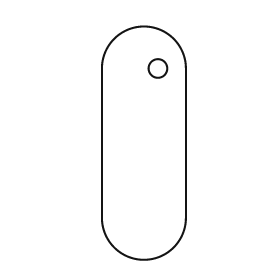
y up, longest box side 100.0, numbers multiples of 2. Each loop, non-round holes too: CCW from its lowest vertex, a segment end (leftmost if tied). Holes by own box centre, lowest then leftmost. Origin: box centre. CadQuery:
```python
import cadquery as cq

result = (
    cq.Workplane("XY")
    .moveTo(-18.0, -32.0)
    .threePointArc((0.0, -50.0), (18.0, -32.0))
    .lineTo(18.0, 32.0)
    .threePointArc((0.0, 50.0), (-18.0, 32.0))
    .close()
    .moveTo(6.0, 32.0)
    .circle(4.0)
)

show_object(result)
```